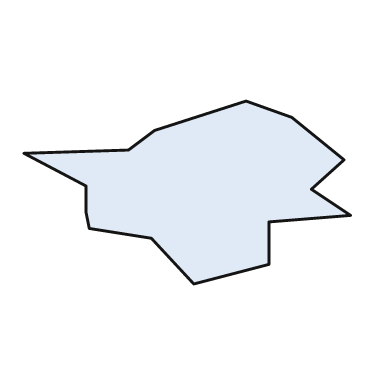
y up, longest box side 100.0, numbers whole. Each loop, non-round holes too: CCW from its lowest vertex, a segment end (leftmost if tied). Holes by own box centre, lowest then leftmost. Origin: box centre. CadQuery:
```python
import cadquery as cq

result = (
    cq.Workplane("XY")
    .moveTo(2.0, -28.0)
    .lineTo(25.0, -22.0)
    .lineTo(25.0, -9.0)
    .lineTo(50.0, -7.0)
    .lineTo(38.0, 1.0)
    .lineTo(48.0, 10.0)
    .lineTo(32.0, 23.0)
    .lineTo(18.0, 28.0)
    .lineTo(-10.0, 19.0)
    .lineTo(-18.0, 13.0)
    .lineTo(-50.0, 12.0)
    .lineTo(-31.0, 2.0)
    .lineTo(-31.0, -6.0)
    .lineTo(-30.0, -11.0)
    .lineTo(-11.0, -14.0)
    .close()
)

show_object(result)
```